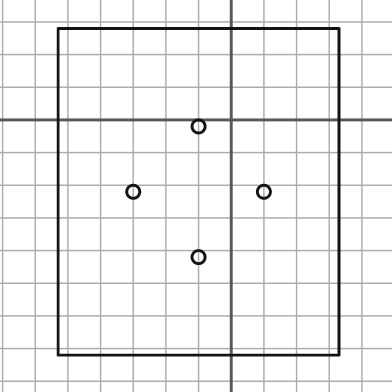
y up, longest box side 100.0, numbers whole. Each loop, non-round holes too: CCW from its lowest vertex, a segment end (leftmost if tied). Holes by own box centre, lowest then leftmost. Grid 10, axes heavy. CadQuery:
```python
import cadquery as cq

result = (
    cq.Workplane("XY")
    .moveTo(-53.0, -72.0)
    .lineTo(33.0, -72.0)
    .lineTo(33.0, 28.0)
    .lineTo(-53.0, 28.0)
    .close()
    .moveTo(-10.0, -42.0)
    .circle(2.0)
    .moveTo(-30.0, -22.0)
    .circle(2.0)
    .moveTo(10.0, -22.0)
    .circle(2.0)
    .moveTo(-10.0, -2.0)
    .circle(2.0)
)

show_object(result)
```